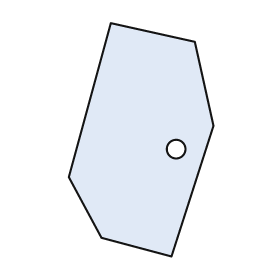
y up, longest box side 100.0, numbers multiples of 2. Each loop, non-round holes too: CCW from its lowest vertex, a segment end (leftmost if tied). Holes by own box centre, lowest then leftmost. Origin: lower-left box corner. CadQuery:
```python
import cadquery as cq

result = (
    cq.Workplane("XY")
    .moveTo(44.0, 0.0)
    .lineTo(62.0, 56.0)
    .lineTo(54.0, 92.0)
    .lineTo(18.0, 100.0)
    .lineTo(0.0, 34.0)
    .lineTo(14.0, 8.0)
    .close()
    .moveTo(46.0, 46.0)
    .circle(4.0)
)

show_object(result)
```